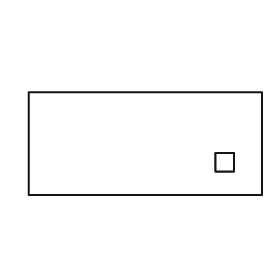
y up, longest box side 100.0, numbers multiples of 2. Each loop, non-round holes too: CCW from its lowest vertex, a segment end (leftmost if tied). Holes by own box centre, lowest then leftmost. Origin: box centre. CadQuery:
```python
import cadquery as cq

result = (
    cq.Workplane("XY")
    .moveTo(-50.0, -22.0)
    .lineTo(50.0, -22.0)
    .lineTo(50.0, 22.0)
    .lineTo(-50.0, 22.0)
    .close()
    .moveTo(30.0, -12.0)
    .lineTo(38.0, -12.0)
    .lineTo(38.0, -4.0)
    .lineTo(30.0, -4.0)
    .close()
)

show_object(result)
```